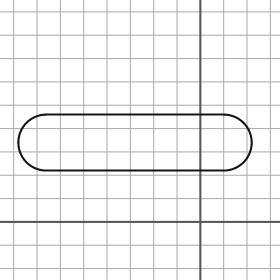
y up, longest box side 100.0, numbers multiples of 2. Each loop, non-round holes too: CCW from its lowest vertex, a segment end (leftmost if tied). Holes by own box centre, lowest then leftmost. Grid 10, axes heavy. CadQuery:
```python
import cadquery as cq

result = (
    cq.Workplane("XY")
    .moveTo(-66.0, 22.0)
    .lineTo(10.0, 22.0)
    .threePointArc((22.0, 34.0), (10.0, 46.0))
    .lineTo(-66.0, 46.0)
    .threePointArc((-78.0, 34.0), (-66.0, 22.0))
    .close()
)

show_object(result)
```